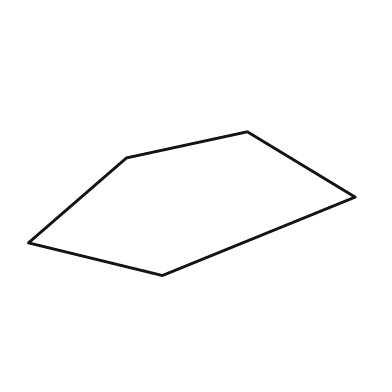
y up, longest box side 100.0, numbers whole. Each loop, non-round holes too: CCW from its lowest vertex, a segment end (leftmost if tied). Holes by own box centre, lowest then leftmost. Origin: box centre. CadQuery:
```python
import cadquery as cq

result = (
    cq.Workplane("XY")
    .moveTo(-9.0, -22.0)
    .lineTo(50.0, 2.0)
    .lineTo(17.0, 22.0)
    .lineTo(-20.0, 14.0)
    .lineTo(-50.0, -12.0)
    .close()
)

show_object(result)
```